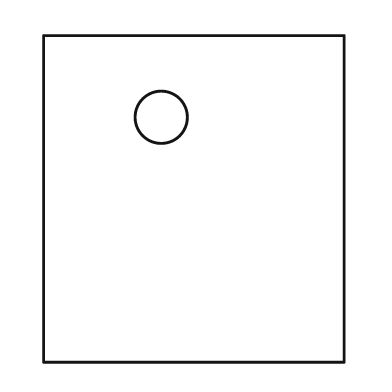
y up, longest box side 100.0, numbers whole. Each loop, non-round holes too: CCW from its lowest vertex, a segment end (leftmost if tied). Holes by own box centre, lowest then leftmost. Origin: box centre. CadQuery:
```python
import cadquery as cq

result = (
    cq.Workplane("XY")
    .moveTo(-46.0, -50.0)
    .lineTo(46.0, -50.0)
    .lineTo(46.0, 50.0)
    .lineTo(-46.0, 50.0)
    .close()
    .moveTo(-10.0, 25.0)
    .circle(8.0)
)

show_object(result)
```